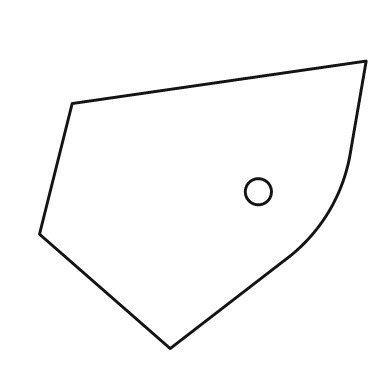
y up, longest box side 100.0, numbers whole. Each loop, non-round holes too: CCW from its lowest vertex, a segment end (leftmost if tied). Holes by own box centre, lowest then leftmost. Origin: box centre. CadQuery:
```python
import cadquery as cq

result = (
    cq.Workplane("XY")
    .moveTo(-10.0, -44.0)
    .lineTo(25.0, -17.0)
    .threePointArc((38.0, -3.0), (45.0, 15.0))
    .lineTo(50.0, 44.0)
    .lineTo(-40.0, 31.0)
    .lineTo(-50.0, -9.0)
    .close()
    .moveTo(17.0, 4.0)
    .circle(4.0)
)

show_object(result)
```